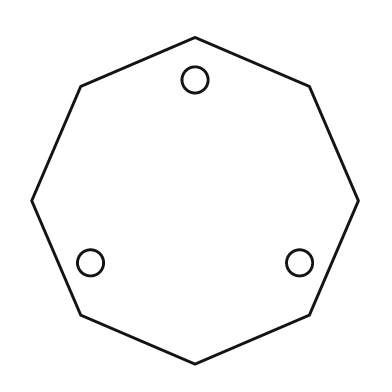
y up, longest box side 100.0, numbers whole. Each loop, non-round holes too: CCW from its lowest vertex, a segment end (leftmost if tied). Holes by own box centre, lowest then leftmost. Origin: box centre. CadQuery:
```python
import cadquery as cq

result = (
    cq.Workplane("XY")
    .moveTo(0.0, -50.0)
    .lineTo(35.0, -35.0)
    .lineTo(50.0, 0.0)
    .lineTo(35.0, 35.0)
    .lineTo(0.0, 50.0)
    .lineTo(-35.0, 35.0)
    .lineTo(-50.0, 0.0)
    .lineTo(-35.0, -35.0)
    .close()
    .moveTo(-32.0, -19.0)
    .circle(4.0)
    .moveTo(32.0, -19.0)
    .circle(4.0)
    .moveTo(0.0, 37.0)
    .circle(4.0)
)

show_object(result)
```